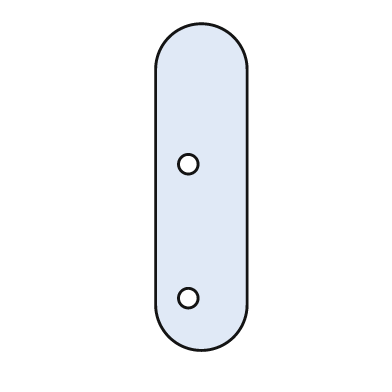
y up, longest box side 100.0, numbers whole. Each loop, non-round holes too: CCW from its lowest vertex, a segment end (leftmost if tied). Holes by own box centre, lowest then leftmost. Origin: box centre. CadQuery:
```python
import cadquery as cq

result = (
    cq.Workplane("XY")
    .moveTo(-14.0, -36.0)
    .threePointArc((0.0, -50.0), (14.0, -36.0))
    .lineTo(14.0, 36.0)
    .threePointArc((0.0, 50.0), (-14.0, 36.0))
    .close()
    .moveTo(-4.0, -34.0)
    .circle(3.0)
    .moveTo(-4.0, 7.0)
    .circle(3.0)
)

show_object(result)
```